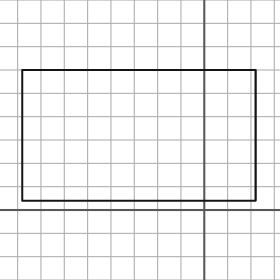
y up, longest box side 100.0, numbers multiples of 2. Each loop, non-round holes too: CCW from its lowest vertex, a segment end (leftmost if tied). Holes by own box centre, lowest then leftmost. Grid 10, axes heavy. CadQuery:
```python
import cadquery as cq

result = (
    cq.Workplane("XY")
    .moveTo(-78.0, 4.0)
    .lineTo(22.0, 4.0)
    .lineTo(22.0, 60.0)
    .lineTo(-78.0, 60.0)
    .close()
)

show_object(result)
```